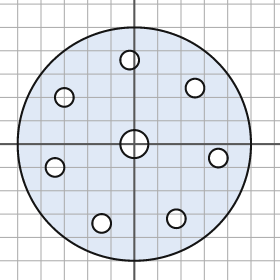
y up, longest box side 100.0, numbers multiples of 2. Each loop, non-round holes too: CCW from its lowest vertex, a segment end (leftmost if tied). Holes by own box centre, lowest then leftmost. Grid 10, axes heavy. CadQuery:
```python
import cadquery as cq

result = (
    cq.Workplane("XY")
    .moveTo(0.0, 0.0)
    .circle(50.0)
    .moveTo(-14.0, -34.0)
    .circle(4.0)
    .moveTo(18.0, -32.0)
    .circle(4.0)
    .moveTo(-34.0, -10.0)
    .circle(4.0)
    .moveTo(36.0, -6.0)
    .circle(4.0)
    .moveTo(0.0, 0.0)
    .circle(6.0)
    .moveTo(-30.0, 20.0)
    .circle(4.0)
    .moveTo(26.0, 24.0)
    .circle(4.0)
    .moveTo(-2.0, 36.0)
    .circle(4.0)
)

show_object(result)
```